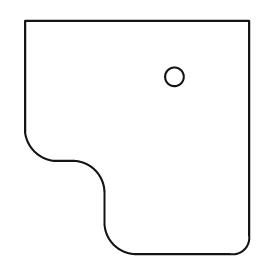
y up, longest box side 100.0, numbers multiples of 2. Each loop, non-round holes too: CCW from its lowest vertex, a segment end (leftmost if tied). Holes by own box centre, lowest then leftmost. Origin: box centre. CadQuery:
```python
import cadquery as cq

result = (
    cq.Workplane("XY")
    .moveTo(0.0, -50.0)
    .lineTo(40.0, -50.0)
    .threePointArc((46.0, -48.0), (48.0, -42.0))
    .lineTo(48.0, 50.0)
    .lineTo(-48.0, 50.0)
    .lineTo(-48.0, 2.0)
    .threePointArc((-44.0, -6.0), (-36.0, -10.0))
    .lineTo(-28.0, -10.0)
    .threePointArc((-18.0, -14.0), (-14.0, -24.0))
    .lineTo(-14.0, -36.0)
    .threePointArc((-10.0, -46.0), (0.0, -50.0))
    .close()
    .moveTo(16.0, 26.0)
    .circle(4.0)
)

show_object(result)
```